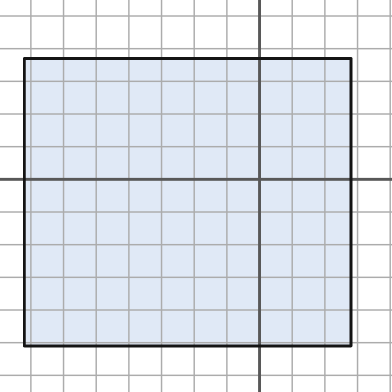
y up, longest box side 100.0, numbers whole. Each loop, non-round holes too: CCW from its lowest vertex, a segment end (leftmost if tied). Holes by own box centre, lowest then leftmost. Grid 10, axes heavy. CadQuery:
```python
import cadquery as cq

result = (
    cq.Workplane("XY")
    .moveTo(-72.0, -51.0)
    .lineTo(28.0, -51.0)
    .lineTo(28.0, 37.0)
    .lineTo(-72.0, 37.0)
    .close()
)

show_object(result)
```